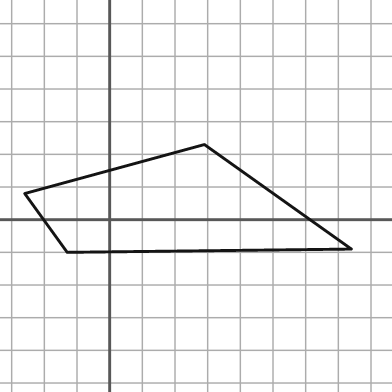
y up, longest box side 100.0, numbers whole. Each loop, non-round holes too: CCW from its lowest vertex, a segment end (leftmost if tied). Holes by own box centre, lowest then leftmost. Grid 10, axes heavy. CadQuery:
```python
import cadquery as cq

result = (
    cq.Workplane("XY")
    .moveTo(-13.0, -10.0)
    .lineTo(74.0, -9.0)
    .lineTo(29.0, 23.0)
    .lineTo(-26.0, 8.0)
    .close()
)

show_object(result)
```